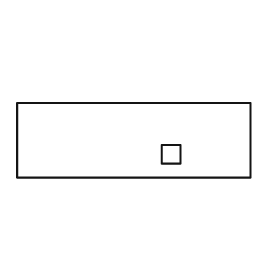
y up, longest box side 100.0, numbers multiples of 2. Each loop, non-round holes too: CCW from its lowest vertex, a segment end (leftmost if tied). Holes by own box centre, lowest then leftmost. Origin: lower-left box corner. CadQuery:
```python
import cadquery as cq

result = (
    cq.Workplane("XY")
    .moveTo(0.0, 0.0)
    .lineTo(100.0, 0.0)
    .lineTo(100.0, 32.0)
    .lineTo(0.0, 32.0)
    .close()
    .moveTo(62.0, 6.0)
    .lineTo(70.0, 6.0)
    .lineTo(70.0, 14.0)
    .lineTo(62.0, 14.0)
    .close()
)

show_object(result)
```